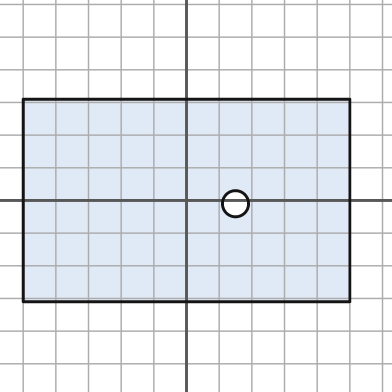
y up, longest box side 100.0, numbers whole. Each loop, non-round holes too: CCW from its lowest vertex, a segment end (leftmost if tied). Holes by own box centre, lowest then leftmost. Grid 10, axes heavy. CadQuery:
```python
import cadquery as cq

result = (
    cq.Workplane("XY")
    .moveTo(-50.0, -31.0)
    .lineTo(50.0, -31.0)
    .lineTo(50.0, 31.0)
    .lineTo(-50.0, 31.0)
    .close()
    .moveTo(15.0, -1.0)
    .circle(4.0)
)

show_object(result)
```